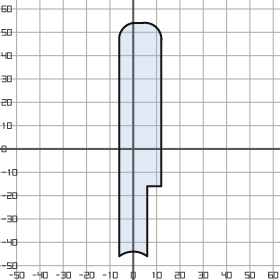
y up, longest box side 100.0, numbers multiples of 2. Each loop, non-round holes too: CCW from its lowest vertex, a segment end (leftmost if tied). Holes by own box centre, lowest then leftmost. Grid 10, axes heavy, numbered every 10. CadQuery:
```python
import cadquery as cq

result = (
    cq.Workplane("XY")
    .moveTo(-6.0, -46.0)
    .threePointArc((0.0, -44.0), (6.0, -46.0))
    .lineTo(6.0, -16.0)
    .lineTo(12.0, -16.0)
    .lineTo(12.0, 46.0)
    .threePointArc((10.0, 52.0), (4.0, 54.0))
    .lineTo(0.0, 54.0)
    .threePointArc((-4.0, 52.0), (-6.0, 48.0))
    .close()
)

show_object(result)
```